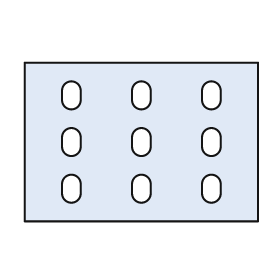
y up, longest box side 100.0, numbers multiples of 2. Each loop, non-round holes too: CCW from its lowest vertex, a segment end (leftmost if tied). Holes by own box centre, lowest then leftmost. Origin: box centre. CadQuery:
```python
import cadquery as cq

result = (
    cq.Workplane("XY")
    .moveTo(-50.0, -34.0)
    .lineTo(50.0, -34.0)
    .lineTo(50.0, 34.0)
    .lineTo(-50.0, 34.0)
    .close()
    .moveTo(-34.0, -22.0)
    .threePointArc((-30.0, -26.0), (-26.0, -22.0))
    .lineTo(-26.0, -18.0)
    .threePointArc((-30.0, -14.0), (-34.0, -18.0))
    .close()
    .moveTo(-4.0, -22.0)
    .threePointArc((0.0, -26.0), (4.0, -22.0))
    .lineTo(4.0, -18.0)
    .threePointArc((0.0, -14.0), (-4.0, -18.0))
    .close()
    .moveTo(26.0, -22.0)
    .threePointArc((30.0, -26.0), (34.0, -22.0))
    .lineTo(34.0, -18.0)
    .threePointArc((30.0, -14.0), (26.0, -18.0))
    .close()
    .moveTo(-34.0, -2.0)
    .threePointArc((-30.0, -6.0), (-26.0, -2.0))
    .lineTo(-26.0, 2.0)
    .threePointArc((-30.0, 6.0), (-34.0, 2.0))
    .close()
    .moveTo(-4.0, -2.0)
    .threePointArc((0.0, -6.0), (4.0, -2.0))
    .lineTo(4.0, 2.0)
    .threePointArc((0.0, 6.0), (-4.0, 2.0))
    .close()
    .moveTo(26.0, -2.0)
    .threePointArc((30.0, -6.0), (34.0, -2.0))
    .lineTo(34.0, 2.0)
    .threePointArc((30.0, 6.0), (26.0, 2.0))
    .close()
    .moveTo(-34.0, 18.0)
    .threePointArc((-30.0, 14.0), (-26.0, 18.0))
    .lineTo(-26.0, 22.0)
    .threePointArc((-30.0, 26.0), (-34.0, 22.0))
    .close()
    .moveTo(-4.0, 18.0)
    .threePointArc((0.0, 14.0), (4.0, 18.0))
    .lineTo(4.0, 22.0)
    .threePointArc((0.0, 26.0), (-4.0, 22.0))
    .close()
    .moveTo(26.0, 18.0)
    .threePointArc((30.0, 14.0), (34.0, 18.0))
    .lineTo(34.0, 22.0)
    .threePointArc((30.0, 26.0), (26.0, 22.0))
    .close()
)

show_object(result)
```